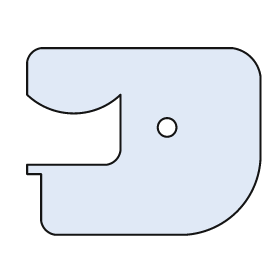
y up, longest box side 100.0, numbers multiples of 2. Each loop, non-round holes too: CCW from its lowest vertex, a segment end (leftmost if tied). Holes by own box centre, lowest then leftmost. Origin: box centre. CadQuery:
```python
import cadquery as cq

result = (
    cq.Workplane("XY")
    .moveTo(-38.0, -40.0)
    .lineTo(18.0, -40.0)
    .threePointArc((40.0, -30.0), (50.0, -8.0))
    .lineTo(50.0, 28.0)
    .threePointArc((46.0, 36.0), (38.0, 40.0))
    .lineTo(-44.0, 40.0)
    .threePointArc((-48.0, 38.0), (-50.0, 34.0))
    .lineTo(-50.0, 20.0)
    .threePointArc((-30.0, 12.0), (-10.0, 20.0))
    .lineTo(-10.0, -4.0)
    .threePointArc((-12.0, -8.0), (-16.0, -10.0))
    .lineTo(-50.0, -10.0)
    .lineTo(-50.0, -14.0)
    .lineTo(-44.0, -14.0)
    .lineTo(-44.0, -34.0)
    .threePointArc((-42.0, -38.0), (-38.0, -40.0))
    .close()
    .moveTo(10.0, 6.0)
    .circle(4.0)
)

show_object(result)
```